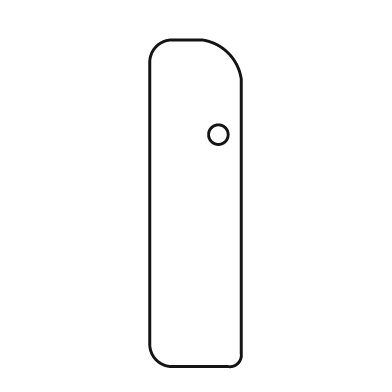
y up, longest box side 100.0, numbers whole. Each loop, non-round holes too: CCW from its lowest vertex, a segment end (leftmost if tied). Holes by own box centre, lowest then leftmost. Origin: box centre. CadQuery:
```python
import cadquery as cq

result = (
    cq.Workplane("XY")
    .moveTo(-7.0, -50.0)
    .lineTo(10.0, -50.0)
    .threePointArc((13.0, -49.0), (14.0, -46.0))
    .lineTo(14.0, 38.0)
    .threePointArc((10.0, 46.0), (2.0, 50.0))
    .lineTo(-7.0, 50.0)
    .threePointArc((-12.0, 48.0), (-14.0, 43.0))
    .lineTo(-14.0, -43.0)
    .threePointArc((-12.0, -48.0), (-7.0, -50.0))
    .close()
    .moveTo(7.0, 21.0)
    .circle(3.0)
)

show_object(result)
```